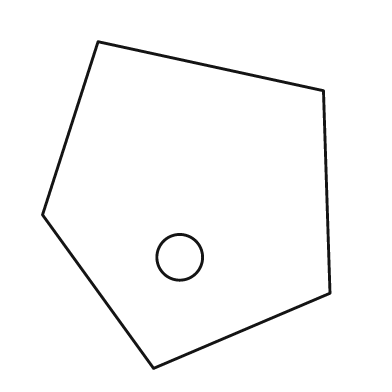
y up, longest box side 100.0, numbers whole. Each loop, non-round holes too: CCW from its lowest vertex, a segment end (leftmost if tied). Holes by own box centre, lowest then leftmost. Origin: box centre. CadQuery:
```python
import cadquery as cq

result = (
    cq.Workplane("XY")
    .moveTo(-10.0, -50.0)
    .lineTo(44.0, -27.0)
    .lineTo(42.0, 35.0)
    .lineTo(-27.0, 50.0)
    .lineTo(-44.0, -3.0)
    .close()
    .moveTo(-2.0, -16.0)
    .circle(7.0)
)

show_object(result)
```